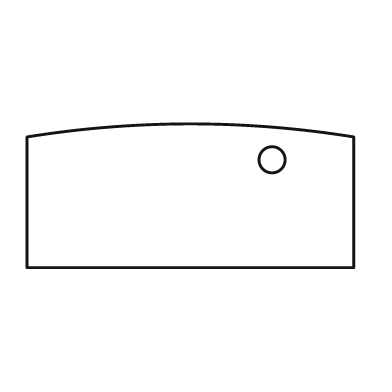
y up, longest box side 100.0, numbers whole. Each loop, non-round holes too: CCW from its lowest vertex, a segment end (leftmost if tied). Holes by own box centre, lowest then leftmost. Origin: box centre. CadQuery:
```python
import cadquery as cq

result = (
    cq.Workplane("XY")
    .moveTo(-50.0, -22.0)
    .lineTo(50.0, -22.0)
    .lineTo(50.0, 18.0)
    .threePointArc((0.0, 22.0), (-50.0, 18.0))
    .close()
    .moveTo(25.0, 11.0)
    .circle(4.0)
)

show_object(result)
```